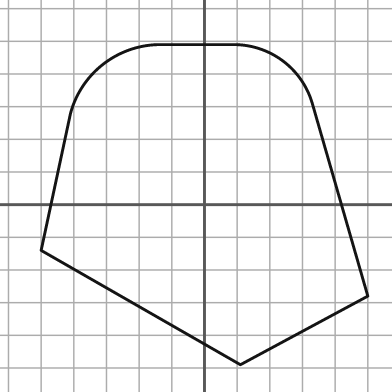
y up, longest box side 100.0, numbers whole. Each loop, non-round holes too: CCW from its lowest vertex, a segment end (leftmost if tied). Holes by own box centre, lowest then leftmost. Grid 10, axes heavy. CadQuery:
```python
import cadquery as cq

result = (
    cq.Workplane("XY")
    .moveTo(11.0, -49.0)
    .lineTo(50.0, -28.0)
    .lineTo(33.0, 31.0)
    .threePointArc((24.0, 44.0), (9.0, 49.0))
    .lineTo(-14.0, 49.0)
    .threePointArc((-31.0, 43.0), (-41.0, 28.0))
    .lineTo(-50.0, -14.0)
    .close()
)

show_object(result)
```